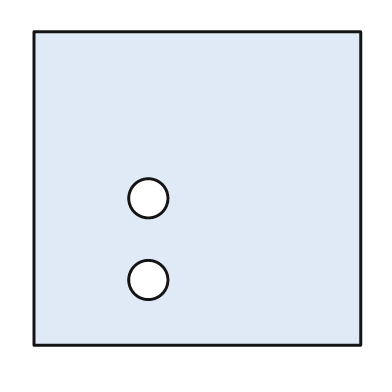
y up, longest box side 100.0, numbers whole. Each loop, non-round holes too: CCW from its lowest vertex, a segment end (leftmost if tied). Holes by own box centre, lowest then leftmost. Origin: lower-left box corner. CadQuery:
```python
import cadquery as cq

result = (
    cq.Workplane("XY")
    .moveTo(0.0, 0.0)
    .lineTo(100.0, 0.0)
    .lineTo(100.0, 96.0)
    .lineTo(0.0, 96.0)
    .close()
    .moveTo(35.0, 20.0)
    .circle(6.0)
    .moveTo(35.0, 45.0)
    .circle(6.0)
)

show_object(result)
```